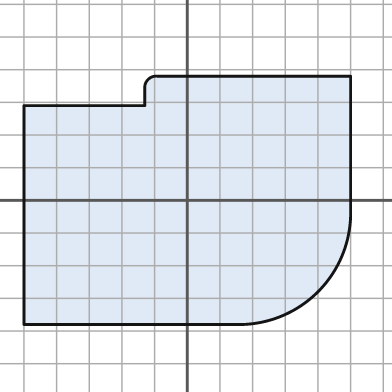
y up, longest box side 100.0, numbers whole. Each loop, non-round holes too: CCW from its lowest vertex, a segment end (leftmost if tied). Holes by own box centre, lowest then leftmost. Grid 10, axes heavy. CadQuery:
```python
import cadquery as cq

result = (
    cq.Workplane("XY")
    .moveTo(-50.0, -38.0)
    .lineTo(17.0, -38.0)
    .threePointArc((40.0, -28.0), (50.0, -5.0))
    .lineTo(50.0, 38.0)
    .lineTo(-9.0, 38.0)
    .threePointArc((-12.0, 37.0), (-13.0, 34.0))
    .lineTo(-13.0, 29.0)
    .lineTo(-50.0, 29.0)
    .close()
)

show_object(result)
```